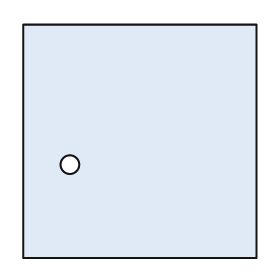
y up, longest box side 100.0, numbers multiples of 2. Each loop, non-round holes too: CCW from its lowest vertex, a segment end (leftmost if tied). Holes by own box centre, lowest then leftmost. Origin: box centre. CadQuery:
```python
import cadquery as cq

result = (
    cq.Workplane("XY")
    .moveTo(-50.0, -50.0)
    .lineTo(50.0, -50.0)
    .lineTo(50.0, 50.0)
    .lineTo(-50.0, 50.0)
    .close()
    .moveTo(-30.0, -10.0)
    .circle(4.0)
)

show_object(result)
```